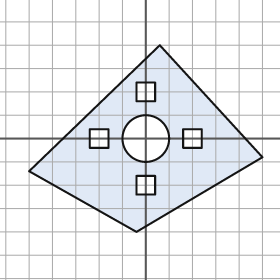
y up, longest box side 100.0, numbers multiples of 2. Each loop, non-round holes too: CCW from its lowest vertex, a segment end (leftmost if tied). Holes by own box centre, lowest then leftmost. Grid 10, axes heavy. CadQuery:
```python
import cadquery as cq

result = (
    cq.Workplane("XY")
    .moveTo(-4.0, -40.0)
    .lineTo(50.0, -8.0)
    .lineTo(6.0, 40.0)
    .lineTo(-50.0, -14.0)
    .close()
    .moveTo(-4.0, -24.0)
    .lineTo(4.0, -24.0)
    .lineTo(4.0, -16.0)
    .lineTo(-4.0, -16.0)
    .close()
    .moveTo(-24.0, -4.0)
    .lineTo(-16.0, -4.0)
    .lineTo(-16.0, 4.0)
    .lineTo(-24.0, 4.0)
    .close()
    .moveTo(0.0, 0.0)
    .circle(10.0)
    .moveTo(16.0, -4.0)
    .lineTo(24.0, -4.0)
    .lineTo(24.0, 4.0)
    .lineTo(16.0, 4.0)
    .close()
    .moveTo(-4.0, 16.0)
    .lineTo(4.0, 16.0)
    .lineTo(4.0, 24.0)
    .lineTo(-4.0, 24.0)
    .close()
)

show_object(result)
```